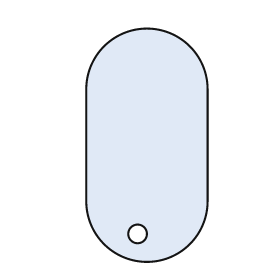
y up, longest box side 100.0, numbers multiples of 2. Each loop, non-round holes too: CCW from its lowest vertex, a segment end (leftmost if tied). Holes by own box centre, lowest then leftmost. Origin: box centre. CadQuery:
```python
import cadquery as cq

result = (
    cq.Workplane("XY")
    .moveTo(-26.0, -24.0)
    .threePointArc((0.0, -50.0), (26.0, -24.0))
    .lineTo(26.0, 24.0)
    .threePointArc((0.0, 50.0), (-26.0, 24.0))
    .close()
    .moveTo(-4.0, -38.0)
    .circle(4.0)
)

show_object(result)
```